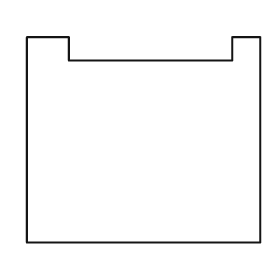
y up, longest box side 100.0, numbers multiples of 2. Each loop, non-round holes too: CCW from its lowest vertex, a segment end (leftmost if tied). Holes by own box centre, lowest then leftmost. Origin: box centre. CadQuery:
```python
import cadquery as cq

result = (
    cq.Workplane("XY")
    .moveTo(-50.0, -44.0)
    .lineTo(50.0, -44.0)
    .lineTo(50.0, 44.0)
    .lineTo(38.0, 44.0)
    .lineTo(38.0, 34.0)
    .lineTo(-32.0, 34.0)
    .lineTo(-32.0, 44.0)
    .lineTo(-50.0, 44.0)
    .close()
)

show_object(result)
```